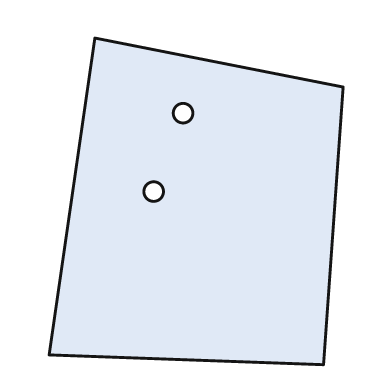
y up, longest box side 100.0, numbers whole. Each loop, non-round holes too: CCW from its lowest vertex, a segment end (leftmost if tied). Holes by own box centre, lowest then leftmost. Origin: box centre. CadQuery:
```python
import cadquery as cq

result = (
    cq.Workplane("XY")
    .moveTo(39.0, -50.0)
    .lineTo(45.0, 35.0)
    .lineTo(-31.0, 50.0)
    .lineTo(-45.0, -47.0)
    .close()
    .moveTo(-13.0, 3.0)
    .circle(3.0)
    .moveTo(-4.0, 27.0)
    .circle(3.0)
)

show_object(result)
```